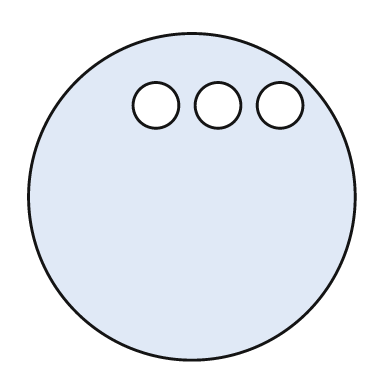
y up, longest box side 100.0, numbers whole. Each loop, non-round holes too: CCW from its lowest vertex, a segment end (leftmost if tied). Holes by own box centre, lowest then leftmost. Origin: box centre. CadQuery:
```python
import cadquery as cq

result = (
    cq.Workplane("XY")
    .moveTo(0.0, 0.0)
    .circle(50.0)
    .moveTo(-11.0, 28.0)
    .circle(7.0)
    .moveTo(8.0, 28.0)
    .circle(7.0)
    .moveTo(27.0, 28.0)
    .circle(7.0)
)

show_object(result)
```